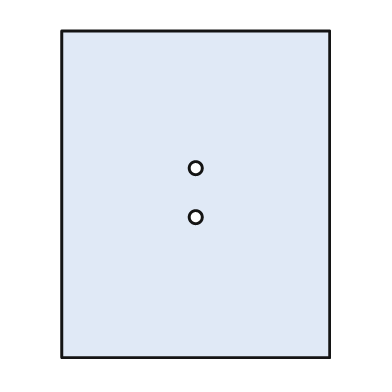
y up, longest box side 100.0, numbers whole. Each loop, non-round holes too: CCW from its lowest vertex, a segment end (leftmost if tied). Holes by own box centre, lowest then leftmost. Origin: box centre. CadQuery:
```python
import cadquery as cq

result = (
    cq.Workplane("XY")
    .moveTo(-41.0, -50.0)
    .lineTo(41.0, -50.0)
    .lineTo(41.0, 50.0)
    .lineTo(-41.0, 50.0)
    .close()
    .moveTo(0.0, -7.0)
    .circle(2.0)
    .moveTo(0.0, 8.0)
    .circle(2.0)
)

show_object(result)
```